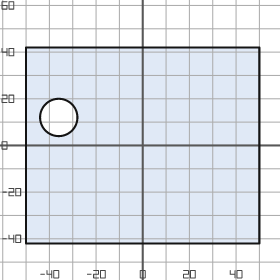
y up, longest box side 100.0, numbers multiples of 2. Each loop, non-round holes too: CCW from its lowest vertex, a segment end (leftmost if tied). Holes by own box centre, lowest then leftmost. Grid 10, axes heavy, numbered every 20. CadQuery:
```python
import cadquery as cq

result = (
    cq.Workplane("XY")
    .moveTo(-50.0, -42.0)
    .lineTo(50.0, -42.0)
    .lineTo(50.0, 42.0)
    .lineTo(-50.0, 42.0)
    .close()
    .moveTo(-36.0, 12.0)
    .circle(8.0)
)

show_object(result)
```